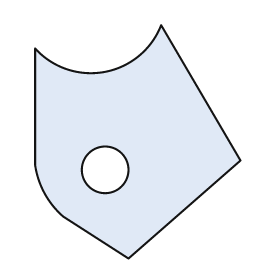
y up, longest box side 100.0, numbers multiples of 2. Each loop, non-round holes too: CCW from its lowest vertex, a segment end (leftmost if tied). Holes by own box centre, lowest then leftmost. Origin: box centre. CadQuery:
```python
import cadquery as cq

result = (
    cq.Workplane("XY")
    .moveTo(-4.0, -50.0)
    .lineTo(44.0, -8.0)
    .lineTo(10.0, 50.0)
    .threePointArc((-14.0, 30.0), (-44.0, 40.0))
    .lineTo(-44.0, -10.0)
    .threePointArc((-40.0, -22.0), (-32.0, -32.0))
    .close()
    .moveTo(-14.0, -12.0)
    .circle(10.0)
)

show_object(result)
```